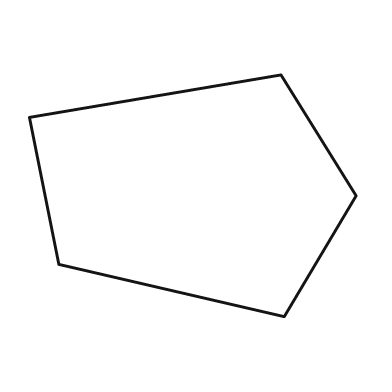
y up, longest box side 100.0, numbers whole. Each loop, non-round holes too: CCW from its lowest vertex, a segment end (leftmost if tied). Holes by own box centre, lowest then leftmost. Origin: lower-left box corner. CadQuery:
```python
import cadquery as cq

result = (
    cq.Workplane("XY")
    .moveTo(78.0, 0.0)
    .lineTo(100.0, 37.0)
    .lineTo(77.0, 74.0)
    .lineTo(0.0, 61.0)
    .lineTo(9.0, 16.0)
    .close()
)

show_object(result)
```